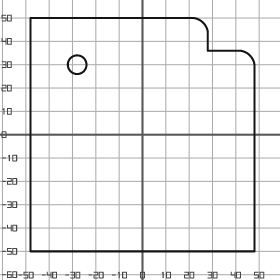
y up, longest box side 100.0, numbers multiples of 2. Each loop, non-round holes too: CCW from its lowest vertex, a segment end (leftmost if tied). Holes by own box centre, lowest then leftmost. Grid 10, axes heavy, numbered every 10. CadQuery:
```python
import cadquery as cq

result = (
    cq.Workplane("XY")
    .moveTo(-48.0, -50.0)
    .lineTo(48.0, -50.0)
    .lineTo(48.0, 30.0)
    .threePointArc((46.0, 34.0), (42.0, 36.0))
    .lineTo(28.0, 36.0)
    .lineTo(28.0, 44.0)
    .threePointArc((26.0, 48.0), (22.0, 50.0))
    .lineTo(-48.0, 50.0)
    .close()
    .moveTo(-28.0, 30.0)
    .circle(4.0)
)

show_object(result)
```